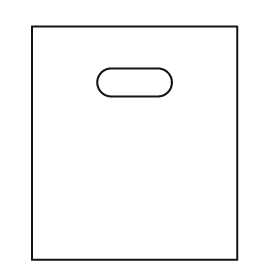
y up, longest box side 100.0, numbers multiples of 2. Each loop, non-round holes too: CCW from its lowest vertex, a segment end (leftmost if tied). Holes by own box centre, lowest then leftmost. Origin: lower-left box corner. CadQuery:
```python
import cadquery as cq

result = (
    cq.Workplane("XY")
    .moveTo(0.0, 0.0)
    .lineTo(88.0, 0.0)
    .lineTo(88.0, 100.0)
    .lineTo(0.0, 100.0)
    .close()
    .moveTo(34.0, 70.0)
    .lineTo(54.0, 70.0)
    .threePointArc((60.0, 76.0), (54.0, 82.0))
    .lineTo(34.0, 82.0)
    .threePointArc((28.0, 76.0), (34.0, 70.0))
    .close()
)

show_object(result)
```